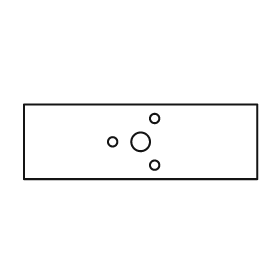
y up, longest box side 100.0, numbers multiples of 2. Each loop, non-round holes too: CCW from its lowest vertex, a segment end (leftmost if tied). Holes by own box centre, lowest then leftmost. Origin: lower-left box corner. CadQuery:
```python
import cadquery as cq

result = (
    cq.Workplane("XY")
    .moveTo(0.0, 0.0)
    .lineTo(100.0, 0.0)
    .lineTo(100.0, 32.0)
    .lineTo(0.0, 32.0)
    .close()
    .moveTo(56.0, 6.0)
    .circle(2.0)
    .moveTo(38.0, 16.0)
    .circle(2.0)
    .moveTo(50.0, 16.0)
    .circle(4.0)
    .moveTo(56.0, 26.0)
    .circle(2.0)
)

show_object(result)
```